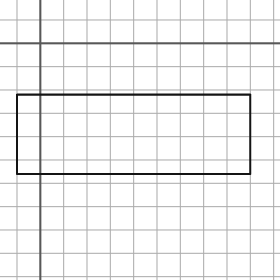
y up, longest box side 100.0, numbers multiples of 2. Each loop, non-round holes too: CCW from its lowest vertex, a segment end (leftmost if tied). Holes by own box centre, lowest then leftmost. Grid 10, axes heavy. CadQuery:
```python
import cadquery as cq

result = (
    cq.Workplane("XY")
    .moveTo(-10.0, -56.0)
    .lineTo(90.0, -56.0)
    .lineTo(90.0, -22.0)
    .lineTo(-10.0, -22.0)
    .close()
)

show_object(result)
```